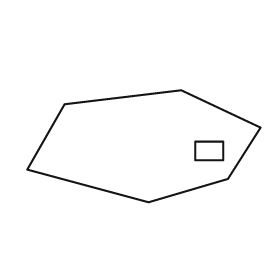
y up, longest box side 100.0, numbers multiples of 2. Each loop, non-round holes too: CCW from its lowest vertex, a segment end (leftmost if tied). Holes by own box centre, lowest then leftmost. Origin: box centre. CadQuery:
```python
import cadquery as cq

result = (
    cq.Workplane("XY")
    .moveTo(2.0, -24.0)
    .lineTo(36.0, -14.0)
    .lineTo(50.0, 8.0)
    .lineTo(16.0, 24.0)
    .lineTo(-34.0, 18.0)
    .lineTo(-50.0, -10.0)
    .close()
    .moveTo(22.0, -6.0)
    .lineTo(34.0, -6.0)
    .lineTo(34.0, 2.0)
    .lineTo(22.0, 2.0)
    .close()
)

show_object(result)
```